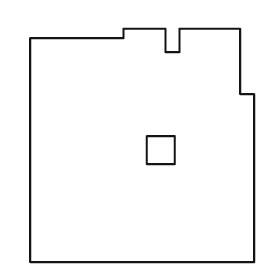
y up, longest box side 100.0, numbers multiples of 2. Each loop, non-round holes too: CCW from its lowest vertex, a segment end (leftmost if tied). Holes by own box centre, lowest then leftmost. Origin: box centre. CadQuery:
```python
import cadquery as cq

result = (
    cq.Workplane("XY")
    .moveTo(-48.0, -50.0)
    .lineTo(48.0, -50.0)
    .lineTo(48.0, 22.0)
    .lineTo(42.0, 22.0)
    .lineTo(42.0, 50.0)
    .lineTo(16.0, 50.0)
    .lineTo(16.0, 40.0)
    .lineTo(10.0, 40.0)
    .lineTo(10.0, 50.0)
    .lineTo(-8.0, 50.0)
    .lineTo(-8.0, 46.0)
    .lineTo(-48.0, 46.0)
    .close()
    .moveTo(2.0, -8.0)
    .lineTo(14.0, -8.0)
    .lineTo(14.0, 4.0)
    .lineTo(2.0, 4.0)
    .close()
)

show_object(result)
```